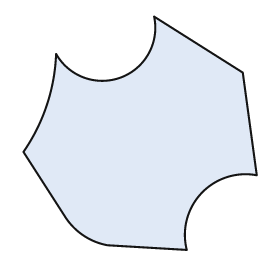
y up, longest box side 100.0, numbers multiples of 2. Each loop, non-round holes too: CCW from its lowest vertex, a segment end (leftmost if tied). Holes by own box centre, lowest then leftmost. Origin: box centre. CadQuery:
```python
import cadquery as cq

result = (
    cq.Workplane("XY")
    .moveTo(20.0, -50.0)
    .threePointArc((26.0, -26.0), (50.0, -18.0))
    .lineTo(44.0, 26.0)
    .lineTo(6.0, 50.0)
    .threePointArc((-8.0, 24.0), (-36.0, 34.0))
    .threePointArc((-40.0, 12.0), (-50.0, -8.0))
    .lineTo(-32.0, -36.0)
    .threePointArc((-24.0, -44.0), (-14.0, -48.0))
    .close()
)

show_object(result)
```